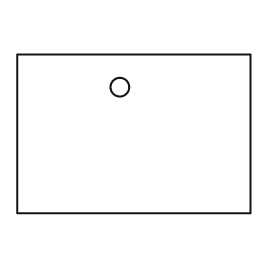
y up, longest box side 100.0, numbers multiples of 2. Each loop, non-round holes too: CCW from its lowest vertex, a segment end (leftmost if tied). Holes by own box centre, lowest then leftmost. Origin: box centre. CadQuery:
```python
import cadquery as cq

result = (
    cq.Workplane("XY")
    .moveTo(-50.0, -34.0)
    .lineTo(50.0, -34.0)
    .lineTo(50.0, 34.0)
    .lineTo(-50.0, 34.0)
    .close()
    .moveTo(-6.0, 20.0)
    .circle(4.0)
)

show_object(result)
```